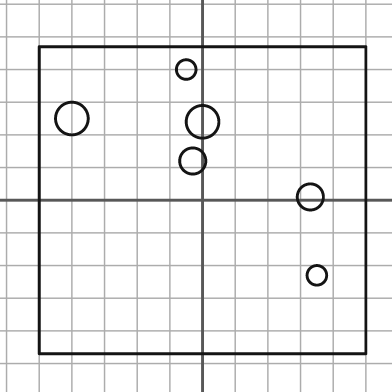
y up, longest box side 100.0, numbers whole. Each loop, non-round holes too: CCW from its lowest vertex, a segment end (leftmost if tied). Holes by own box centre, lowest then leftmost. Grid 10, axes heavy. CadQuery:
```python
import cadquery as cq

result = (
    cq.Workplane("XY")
    .moveTo(-50.0, -47.0)
    .lineTo(50.0, -47.0)
    .lineTo(50.0, 47.0)
    .lineTo(-50.0, 47.0)
    .close()
    .moveTo(35.0, -23.0)
    .circle(3.0)
    .moveTo(33.0, 1.0)
    .circle(4.0)
    .moveTo(-3.0, 12.0)
    .circle(4.0)
    .moveTo(0.0, 24.0)
    .circle(5.0)
    .moveTo(-40.0, 25.0)
    .circle(5.0)
    .moveTo(-5.0, 40.0)
    .circle(3.0)
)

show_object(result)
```